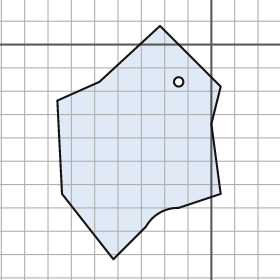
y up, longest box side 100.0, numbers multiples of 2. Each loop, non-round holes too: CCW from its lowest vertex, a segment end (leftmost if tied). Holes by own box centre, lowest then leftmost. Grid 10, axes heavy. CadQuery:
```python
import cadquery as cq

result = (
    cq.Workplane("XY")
    .moveTo(-42.0, -92.0)
    .lineTo(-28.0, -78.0)
    .threePointArc((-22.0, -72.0), (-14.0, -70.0))
    .lineTo(4.0, -64.0)
    .lineTo(0.0, -34.0)
    .lineTo(4.0, -18.0)
    .lineTo(-22.0, 8.0)
    .lineTo(-48.0, -16.0)
    .lineTo(-66.0, -24.0)
    .lineTo(-64.0, -64.0)
    .close()
    .moveTo(-14.0, -16.0)
    .circle(2.0)
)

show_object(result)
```